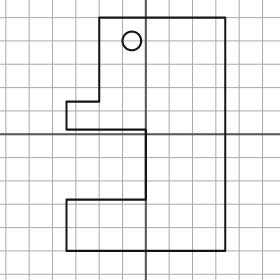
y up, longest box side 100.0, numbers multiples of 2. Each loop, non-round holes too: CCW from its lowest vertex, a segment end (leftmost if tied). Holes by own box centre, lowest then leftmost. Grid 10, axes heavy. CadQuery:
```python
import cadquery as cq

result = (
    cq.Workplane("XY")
    .moveTo(-34.0, -50.0)
    .lineTo(34.0, -50.0)
    .lineTo(34.0, 50.0)
    .lineTo(-20.0, 50.0)
    .lineTo(-20.0, 14.0)
    .lineTo(-34.0, 14.0)
    .lineTo(-34.0, 2.0)
    .lineTo(0.0, 2.0)
    .lineTo(0.0, -28.0)
    .lineTo(-34.0, -28.0)
    .close()
    .moveTo(-6.0, 40.0)
    .circle(4.0)
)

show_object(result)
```